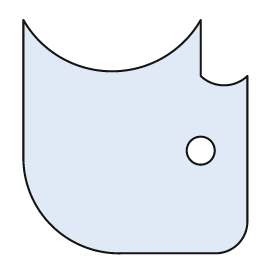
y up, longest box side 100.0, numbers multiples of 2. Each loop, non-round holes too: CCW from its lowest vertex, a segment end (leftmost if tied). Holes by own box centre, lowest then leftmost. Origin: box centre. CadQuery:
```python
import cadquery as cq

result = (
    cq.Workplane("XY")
    .moveTo(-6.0, -50.0)
    .lineTo(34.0, -50.0)
    .threePointArc((44.0, -46.0), (48.0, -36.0))
    .lineTo(48.0, 26.0)
    .threePointArc((38.0, 22.0), (28.0, 26.0))
    .lineTo(28.0, 50.0)
    .threePointArc((-10.0, 28.0), (-48.0, 50.0))
    .lineTo(-48.0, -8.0)
    .threePointArc((-36.0, -38.0), (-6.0, -50.0))
    .close()
    .moveTo(28.0, -6.0)
    .circle(6.0)
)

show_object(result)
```